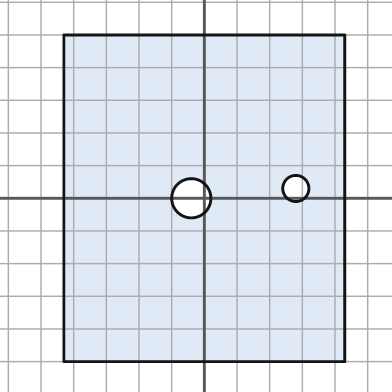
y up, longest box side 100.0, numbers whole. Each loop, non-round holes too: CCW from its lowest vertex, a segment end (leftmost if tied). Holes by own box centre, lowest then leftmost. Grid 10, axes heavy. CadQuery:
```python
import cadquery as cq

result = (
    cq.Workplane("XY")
    .moveTo(-43.0, -50.0)
    .lineTo(43.0, -50.0)
    .lineTo(43.0, 50.0)
    .lineTo(-43.0, 50.0)
    .close()
    .moveTo(-4.0, 0.0)
    .circle(6.0)
    .moveTo(28.0, 3.0)
    .circle(4.0)
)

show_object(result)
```